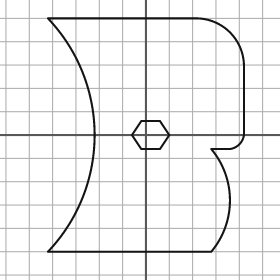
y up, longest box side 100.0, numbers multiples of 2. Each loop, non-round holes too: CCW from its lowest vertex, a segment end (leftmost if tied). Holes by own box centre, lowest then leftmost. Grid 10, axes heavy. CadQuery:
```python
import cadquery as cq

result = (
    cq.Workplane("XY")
    .moveTo(-42.0, -50.0)
    .lineTo(28.0, -50.0)
    .threePointArc((36.0, -28.0), (28.0, -6.0))
    .lineTo(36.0, -6.0)
    .threePointArc((40.0, -4.0), (42.0, 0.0))
    .lineTo(42.0, 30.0)
    .threePointArc((36.0, 44.0), (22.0, 50.0))
    .lineTo(-42.0, 50.0)
    .threePointArc((-22.0, 0.0), (-42.0, -50.0))
    .close()
    .moveTo(-2.0, -6.0)
    .lineTo(6.0, -6.0)
    .lineTo(10.0, 0.0)
    .lineTo(6.0, 6.0)
    .lineTo(-2.0, 6.0)
    .lineTo(-6.0, 0.0)
    .close()
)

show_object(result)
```